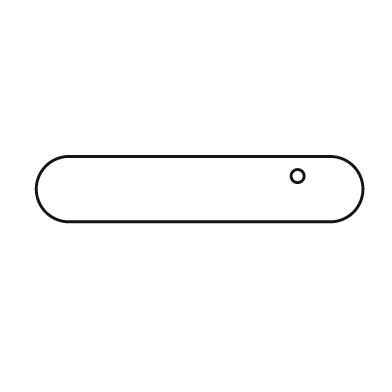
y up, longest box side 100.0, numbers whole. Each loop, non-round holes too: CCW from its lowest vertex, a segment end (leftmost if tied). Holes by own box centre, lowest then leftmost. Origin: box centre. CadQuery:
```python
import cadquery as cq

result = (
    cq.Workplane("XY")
    .moveTo(-40.0, -10.0)
    .lineTo(40.0, -10.0)
    .threePointArc((50.0, 0.0), (40.0, 10.0))
    .lineTo(-40.0, 10.0)
    .threePointArc((-50.0, 0.0), (-40.0, -10.0))
    .close()
    .moveTo(30.0, 4.0)
    .circle(2.0)
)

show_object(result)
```